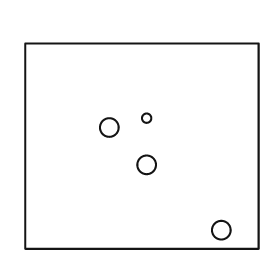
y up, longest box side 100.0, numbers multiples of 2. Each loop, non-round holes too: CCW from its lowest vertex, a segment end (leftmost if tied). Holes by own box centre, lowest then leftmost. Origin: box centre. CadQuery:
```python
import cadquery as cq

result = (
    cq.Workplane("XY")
    .moveTo(-50.0, -44.0)
    .lineTo(50.0, -44.0)
    .lineTo(50.0, 44.0)
    .lineTo(-50.0, 44.0)
    .close()
    .moveTo(34.0, -36.0)
    .circle(4.0)
    .moveTo(2.0, -8.0)
    .circle(4.0)
    .moveTo(-14.0, 8.0)
    .circle(4.0)
    .moveTo(2.0, 12.0)
    .circle(2.0)
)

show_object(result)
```